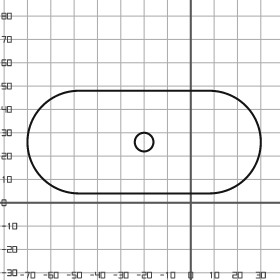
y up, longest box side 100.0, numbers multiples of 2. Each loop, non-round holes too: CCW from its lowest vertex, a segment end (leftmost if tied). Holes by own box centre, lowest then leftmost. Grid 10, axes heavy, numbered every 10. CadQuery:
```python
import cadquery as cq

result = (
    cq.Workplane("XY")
    .moveTo(-48.0, 4.0)
    .lineTo(8.0, 4.0)
    .threePointArc((30.0, 26.0), (8.0, 48.0))
    .lineTo(-48.0, 48.0)
    .threePointArc((-70.0, 26.0), (-48.0, 4.0))
    .close()
    .moveTo(-20.0, 26.0)
    .circle(4.0)
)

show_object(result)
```